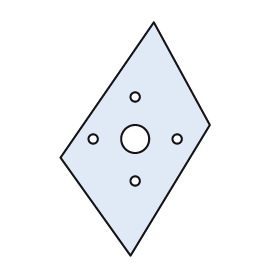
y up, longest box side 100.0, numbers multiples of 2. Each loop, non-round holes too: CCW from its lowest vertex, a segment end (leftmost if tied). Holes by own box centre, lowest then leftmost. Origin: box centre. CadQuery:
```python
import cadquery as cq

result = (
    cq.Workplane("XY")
    .moveTo(-2.0, -50.0)
    .lineTo(32.0, 6.0)
    .lineTo(8.0, 50.0)
    .lineTo(-32.0, -8.0)
    .close()
    .moveTo(0.0, -18.0)
    .circle(2.0)
    .moveTo(-18.0, 0.0)
    .circle(2.0)
    .moveTo(0.0, 0.0)
    .circle(6.0)
    .moveTo(18.0, 0.0)
    .circle(2.0)
    .moveTo(0.0, 18.0)
    .circle(2.0)
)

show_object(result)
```